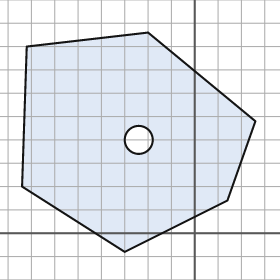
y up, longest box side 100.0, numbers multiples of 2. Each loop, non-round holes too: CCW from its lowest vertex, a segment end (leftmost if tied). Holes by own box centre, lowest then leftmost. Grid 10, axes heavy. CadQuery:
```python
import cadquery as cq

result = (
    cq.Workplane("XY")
    .moveTo(-30.0, -8.0)
    .lineTo(14.0, 14.0)
    .lineTo(26.0, 48.0)
    .lineTo(-20.0, 86.0)
    .lineTo(-72.0, 80.0)
    .lineTo(-74.0, 20.0)
    .close()
    .moveTo(-24.0, 40.0)
    .circle(6.0)
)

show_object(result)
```